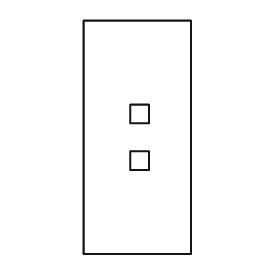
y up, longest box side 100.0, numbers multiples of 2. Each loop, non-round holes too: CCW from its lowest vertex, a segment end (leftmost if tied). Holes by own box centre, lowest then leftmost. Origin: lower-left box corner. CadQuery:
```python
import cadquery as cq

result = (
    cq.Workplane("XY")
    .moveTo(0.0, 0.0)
    .lineTo(46.0, 0.0)
    .lineTo(46.0, 100.0)
    .lineTo(0.0, 100.0)
    .close()
    .moveTo(20.0, 36.0)
    .lineTo(28.0, 36.0)
    .lineTo(28.0, 44.0)
    .lineTo(20.0, 44.0)
    .close()
    .moveTo(20.0, 56.0)
    .lineTo(28.0, 56.0)
    .lineTo(28.0, 64.0)
    .lineTo(20.0, 64.0)
    .close()
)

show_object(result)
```